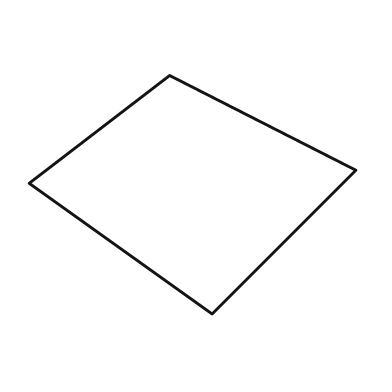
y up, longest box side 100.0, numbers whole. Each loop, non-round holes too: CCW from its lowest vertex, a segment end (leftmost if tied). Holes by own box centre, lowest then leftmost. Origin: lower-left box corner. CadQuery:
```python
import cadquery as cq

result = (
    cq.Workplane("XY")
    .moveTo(56.0, 0.0)
    .lineTo(100.0, 44.0)
    .lineTo(43.0, 73.0)
    .lineTo(0.0, 40.0)
    .close()
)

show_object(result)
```